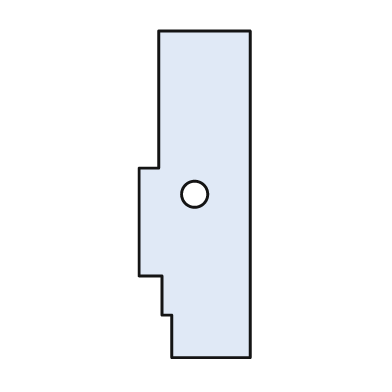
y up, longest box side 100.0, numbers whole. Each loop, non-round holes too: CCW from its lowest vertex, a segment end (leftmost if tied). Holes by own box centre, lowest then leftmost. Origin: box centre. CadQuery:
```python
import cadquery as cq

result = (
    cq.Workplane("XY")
    .moveTo(-7.0, -50.0)
    .lineTo(17.0, -50.0)
    .lineTo(17.0, 50.0)
    .lineTo(-11.0, 50.0)
    .lineTo(-11.0, 8.0)
    .lineTo(-17.0, 8.0)
    .lineTo(-17.0, -25.0)
    .lineTo(-10.0, -25.0)
    .lineTo(-10.0, -37.0)
    .lineTo(-7.0, -37.0)
    .close()
    .moveTo(0.0, 0.0)
    .circle(4.0)
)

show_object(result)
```